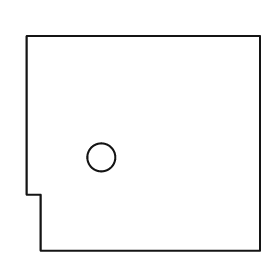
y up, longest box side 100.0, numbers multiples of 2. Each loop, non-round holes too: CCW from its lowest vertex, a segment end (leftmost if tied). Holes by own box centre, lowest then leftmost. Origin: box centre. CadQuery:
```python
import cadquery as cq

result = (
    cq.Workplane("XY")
    .moveTo(-44.0, -46.0)
    .lineTo(50.0, -46.0)
    .lineTo(50.0, 46.0)
    .lineTo(-50.0, 46.0)
    .lineTo(-50.0, -22.0)
    .lineTo(-44.0, -22.0)
    .close()
    .moveTo(-18.0, -6.0)
    .circle(6.0)
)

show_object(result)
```